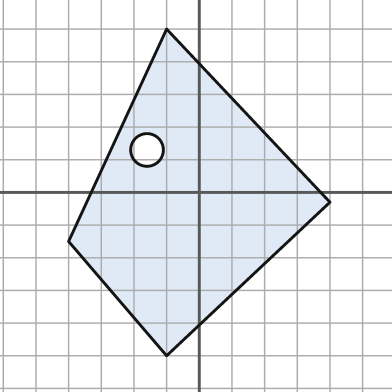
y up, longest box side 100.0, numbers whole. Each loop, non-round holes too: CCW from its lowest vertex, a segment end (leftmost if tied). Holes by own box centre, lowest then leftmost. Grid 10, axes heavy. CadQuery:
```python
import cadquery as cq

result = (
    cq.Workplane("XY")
    .moveTo(-10.0, -50.0)
    .lineTo(40.0, -3.0)
    .lineTo(-10.0, 50.0)
    .lineTo(-40.0, -15.0)
    .close()
    .moveTo(-16.0, 13.0)
    .circle(5.0)
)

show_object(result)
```